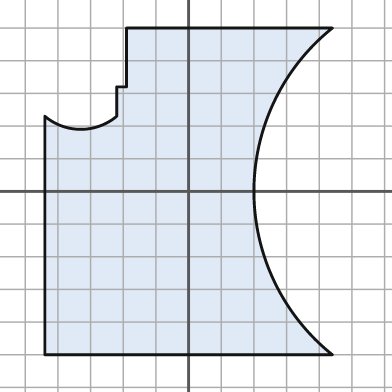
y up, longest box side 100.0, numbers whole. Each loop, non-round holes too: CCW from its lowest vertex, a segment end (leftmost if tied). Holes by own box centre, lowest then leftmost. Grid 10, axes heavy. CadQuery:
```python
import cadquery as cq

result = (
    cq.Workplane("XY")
    .moveTo(-44.0, -50.0)
    .lineTo(44.0, -50.0)
    .threePointArc((20.0, 0.0), (44.0, 50.0))
    .lineTo(-19.0, 50.0)
    .lineTo(-19.0, 32.0)
    .lineTo(-22.0, 32.0)
    .lineTo(-22.0, 23.0)
    .threePointArc((-33.0, 19.0), (-44.0, 23.0))
    .close()
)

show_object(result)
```